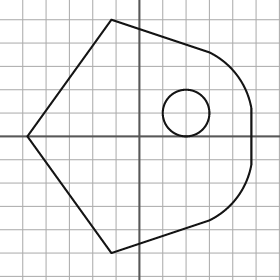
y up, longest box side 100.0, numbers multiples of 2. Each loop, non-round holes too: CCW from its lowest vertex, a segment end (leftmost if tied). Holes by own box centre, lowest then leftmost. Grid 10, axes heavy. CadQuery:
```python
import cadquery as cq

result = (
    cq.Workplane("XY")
    .moveTo(-12.0, -50.0)
    .lineTo(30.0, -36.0)
    .threePointArc((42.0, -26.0), (48.0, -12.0))
    .lineTo(48.0, 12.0)
    .threePointArc((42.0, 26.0), (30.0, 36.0))
    .lineTo(-12.0, 50.0)
    .lineTo(-48.0, 0.0)
    .close()
    .moveTo(20.0, 10.0)
    .circle(10.0)
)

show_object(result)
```